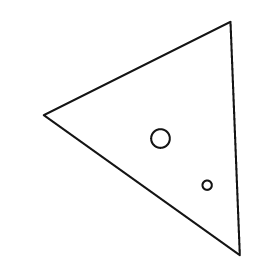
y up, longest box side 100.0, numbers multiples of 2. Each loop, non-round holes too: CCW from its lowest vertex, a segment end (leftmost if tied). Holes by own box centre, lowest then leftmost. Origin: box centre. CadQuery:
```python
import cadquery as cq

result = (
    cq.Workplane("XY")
    .moveTo(42.0, -50.0)
    .lineTo(38.0, 50.0)
    .lineTo(-42.0, 10.0)
    .close()
    .moveTo(28.0, -20.0)
    .circle(2.0)
    .moveTo(8.0, 0.0)
    .circle(4.0)
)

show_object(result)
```